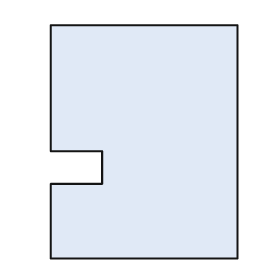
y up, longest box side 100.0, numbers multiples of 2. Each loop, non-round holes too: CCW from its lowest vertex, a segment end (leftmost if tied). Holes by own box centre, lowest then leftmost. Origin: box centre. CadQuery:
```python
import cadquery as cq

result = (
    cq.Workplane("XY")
    .moveTo(-40.0, -50.0)
    .lineTo(40.0, -50.0)
    .lineTo(40.0, 50.0)
    .lineTo(-40.0, 50.0)
    .lineTo(-40.0, -4.0)
    .lineTo(-18.0, -4.0)
    .lineTo(-18.0, -18.0)
    .lineTo(-40.0, -18.0)
    .close()
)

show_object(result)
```